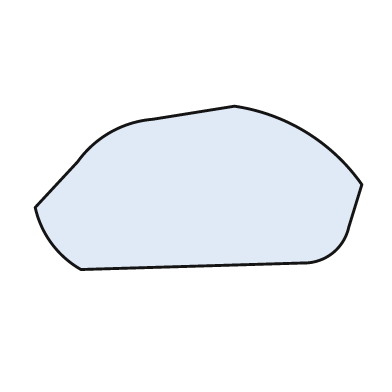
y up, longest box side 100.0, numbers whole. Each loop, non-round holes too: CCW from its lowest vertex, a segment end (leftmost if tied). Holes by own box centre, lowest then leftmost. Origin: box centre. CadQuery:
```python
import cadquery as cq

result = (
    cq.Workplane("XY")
    .moveTo(-36.0, -25.0)
    .lineTo(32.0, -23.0)
    .threePointArc((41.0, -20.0), (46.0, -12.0))
    .lineTo(50.0, 1.0)
    .threePointArc((33.0, 17.0), (11.0, 25.0))
    .lineTo(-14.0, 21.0)
    .threePointArc((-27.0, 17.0), (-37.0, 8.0))
    .lineTo(-50.0, -6.0)
    .threePointArc((-45.0, -17.0), (-36.0, -25.0))
    .close()
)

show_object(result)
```